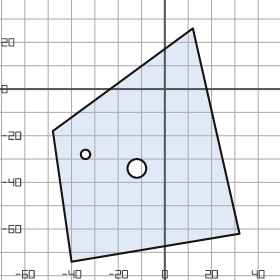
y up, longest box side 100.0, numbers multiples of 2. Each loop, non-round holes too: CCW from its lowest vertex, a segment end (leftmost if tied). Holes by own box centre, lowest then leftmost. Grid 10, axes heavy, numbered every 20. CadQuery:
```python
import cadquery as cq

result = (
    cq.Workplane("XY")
    .moveTo(-40.0, -74.0)
    .lineTo(32.0, -62.0)
    .lineTo(12.0, 26.0)
    .lineTo(-48.0, -18.0)
    .close()
    .moveTo(-12.0, -34.0)
    .circle(4.0)
    .moveTo(-34.0, -28.0)
    .circle(2.0)
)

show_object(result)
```